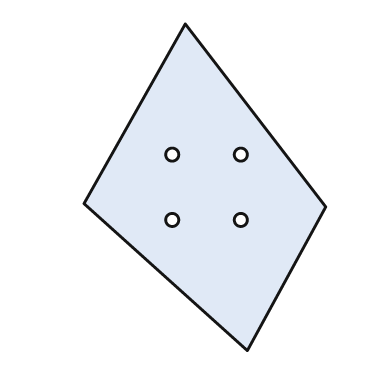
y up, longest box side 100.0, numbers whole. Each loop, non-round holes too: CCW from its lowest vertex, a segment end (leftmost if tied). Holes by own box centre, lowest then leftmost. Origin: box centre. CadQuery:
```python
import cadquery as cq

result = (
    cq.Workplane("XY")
    .moveTo(13.0, -50.0)
    .lineTo(37.0, -6.0)
    .lineTo(-6.0, 50.0)
    .lineTo(-37.0, -5.0)
    .close()
    .moveTo(-10.0, -10.0)
    .circle(2.0)
    .moveTo(11.0, -10.0)
    .circle(2.0)
    .moveTo(-10.0, 10.0)
    .circle(2.0)
    .moveTo(11.0, 10.0)
    .circle(2.0)
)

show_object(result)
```